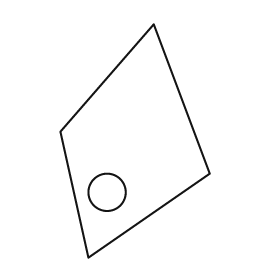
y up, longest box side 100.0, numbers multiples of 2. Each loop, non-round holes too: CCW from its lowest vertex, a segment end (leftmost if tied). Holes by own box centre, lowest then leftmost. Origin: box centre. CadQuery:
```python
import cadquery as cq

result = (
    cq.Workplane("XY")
    .moveTo(-20.0, -50.0)
    .lineTo(32.0, -14.0)
    .lineTo(8.0, 50.0)
    .lineTo(-32.0, 4.0)
    .close()
    .moveTo(-12.0, -22.0)
    .circle(8.0)
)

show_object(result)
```